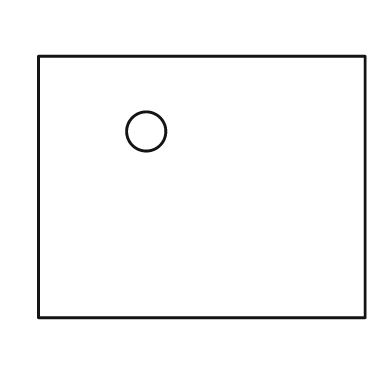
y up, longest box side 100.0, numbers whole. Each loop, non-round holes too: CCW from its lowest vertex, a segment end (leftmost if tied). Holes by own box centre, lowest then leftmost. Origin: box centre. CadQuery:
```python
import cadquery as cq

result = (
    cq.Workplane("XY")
    .moveTo(-50.0, -40.0)
    .lineTo(50.0, -40.0)
    .lineTo(50.0, 40.0)
    .lineTo(-50.0, 40.0)
    .close()
    .moveTo(-17.0, 17.0)
    .circle(6.0)
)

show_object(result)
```